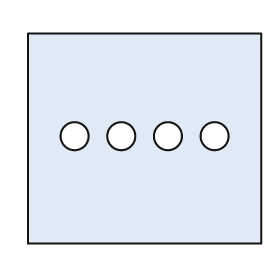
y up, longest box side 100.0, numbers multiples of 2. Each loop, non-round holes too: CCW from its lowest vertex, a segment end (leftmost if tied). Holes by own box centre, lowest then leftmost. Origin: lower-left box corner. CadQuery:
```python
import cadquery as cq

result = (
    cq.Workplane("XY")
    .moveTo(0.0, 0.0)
    .lineTo(100.0, 0.0)
    .lineTo(100.0, 90.0)
    .lineTo(0.0, 90.0)
    .close()
    .moveTo(20.0, 46.0)
    .circle(6.0)
    .moveTo(40.0, 46.0)
    .circle(6.0)
    .moveTo(60.0, 46.0)
    .circle(6.0)
    .moveTo(80.0, 46.0)
    .circle(6.0)
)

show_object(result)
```